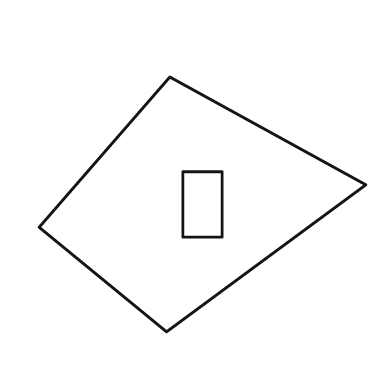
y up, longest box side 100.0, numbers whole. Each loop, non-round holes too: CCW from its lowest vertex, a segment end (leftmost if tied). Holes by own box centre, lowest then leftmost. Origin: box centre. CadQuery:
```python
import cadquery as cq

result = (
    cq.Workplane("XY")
    .moveTo(-11.0, -39.0)
    .lineTo(50.0, 6.0)
    .lineTo(-10.0, 39.0)
    .lineTo(-50.0, -7.0)
    .close()
    .moveTo(-6.0, -10.0)
    .lineTo(6.0, -10.0)
    .lineTo(6.0, 10.0)
    .lineTo(-6.0, 10.0)
    .close()
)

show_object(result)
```